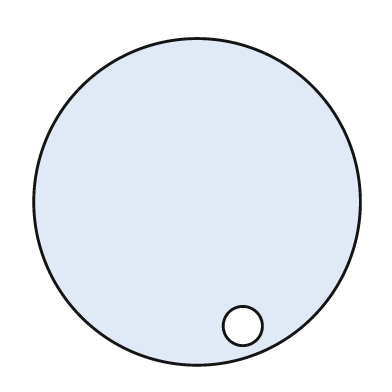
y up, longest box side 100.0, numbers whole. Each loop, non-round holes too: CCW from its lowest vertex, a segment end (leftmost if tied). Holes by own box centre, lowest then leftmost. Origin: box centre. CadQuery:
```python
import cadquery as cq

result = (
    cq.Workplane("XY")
    .moveTo(0.0, 0.0)
    .circle(50.0)
    .moveTo(14.0, -38.0)
    .circle(6.0)
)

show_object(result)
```